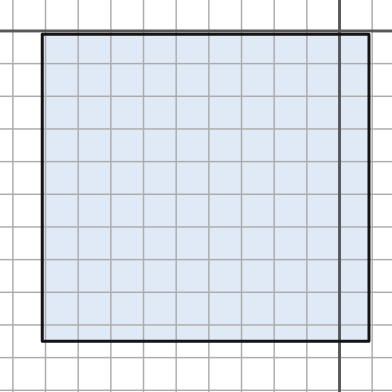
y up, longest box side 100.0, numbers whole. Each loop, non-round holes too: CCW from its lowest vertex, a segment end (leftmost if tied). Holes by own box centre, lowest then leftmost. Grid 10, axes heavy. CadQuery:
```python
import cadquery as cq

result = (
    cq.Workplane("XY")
    .moveTo(-91.0, -95.0)
    .lineTo(9.0, -95.0)
    .lineTo(9.0, -1.0)
    .lineTo(-91.0, -1.0)
    .close()
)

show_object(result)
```